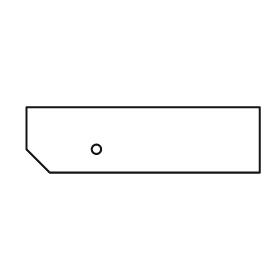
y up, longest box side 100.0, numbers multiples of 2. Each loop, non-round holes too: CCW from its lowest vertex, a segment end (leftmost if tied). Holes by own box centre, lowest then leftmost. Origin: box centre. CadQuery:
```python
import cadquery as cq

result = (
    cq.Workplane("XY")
    .moveTo(-40.0, -14.0)
    .lineTo(50.0, -14.0)
    .lineTo(50.0, 14.0)
    .lineTo(-50.0, 14.0)
    .lineTo(-50.0, -4.0)
    .close()
    .moveTo(-20.0, -4.0)
    .circle(2.0)
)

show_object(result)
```